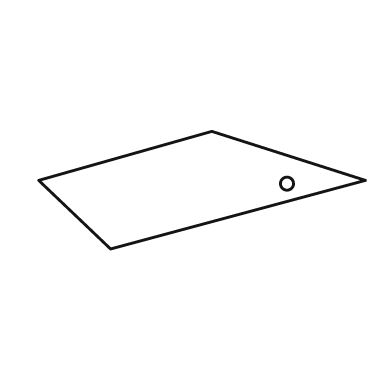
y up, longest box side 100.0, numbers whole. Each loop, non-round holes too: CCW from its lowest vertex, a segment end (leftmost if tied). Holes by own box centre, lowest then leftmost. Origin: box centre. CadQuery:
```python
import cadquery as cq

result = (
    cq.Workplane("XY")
    .moveTo(-28.0, -18.0)
    .lineTo(50.0, 3.0)
    .lineTo(3.0, 18.0)
    .lineTo(-50.0, 3.0)
    .close()
    .moveTo(26.0, 2.0)
    .circle(2.0)
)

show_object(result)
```